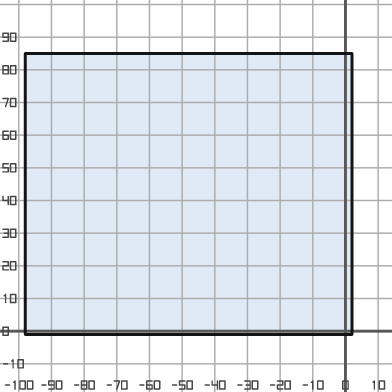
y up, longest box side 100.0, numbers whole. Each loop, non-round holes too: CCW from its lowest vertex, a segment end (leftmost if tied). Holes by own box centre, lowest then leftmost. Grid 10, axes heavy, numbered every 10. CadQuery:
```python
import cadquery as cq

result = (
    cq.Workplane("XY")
    .moveTo(-98.0, -1.0)
    .lineTo(2.0, -1.0)
    .lineTo(2.0, 85.0)
    .lineTo(-98.0, 85.0)
    .close()
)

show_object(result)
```